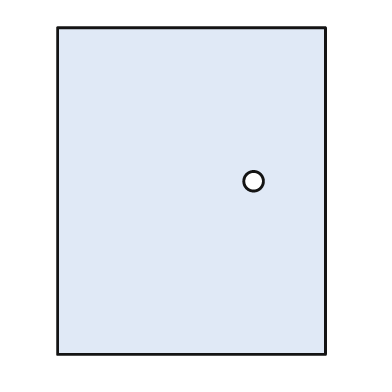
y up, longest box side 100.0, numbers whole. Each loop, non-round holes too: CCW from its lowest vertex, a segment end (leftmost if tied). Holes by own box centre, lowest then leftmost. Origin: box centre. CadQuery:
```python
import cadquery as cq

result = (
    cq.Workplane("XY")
    .moveTo(-41.0, -50.0)
    .lineTo(41.0, -50.0)
    .lineTo(41.0, 50.0)
    .lineTo(-41.0, 50.0)
    .close()
    .moveTo(19.0, 3.0)
    .circle(3.0)
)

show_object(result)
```